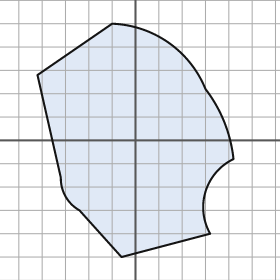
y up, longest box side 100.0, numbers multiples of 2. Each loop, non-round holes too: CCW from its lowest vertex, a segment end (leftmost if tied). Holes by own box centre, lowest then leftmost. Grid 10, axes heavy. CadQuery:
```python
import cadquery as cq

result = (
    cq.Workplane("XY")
    .moveTo(-6.0, -50.0)
    .lineTo(32.0, -40.0)
    .threePointArc((30.0, -22.0), (42.0, -8.0))
    .threePointArc((38.0, 8.0), (30.0, 22.0))
    .threePointArc((14.0, 42.0), (-10.0, 50.0))
    .lineTo(-42.0, 28.0)
    .lineTo(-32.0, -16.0)
    .threePointArc((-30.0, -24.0), (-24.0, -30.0))
    .close()
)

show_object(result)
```